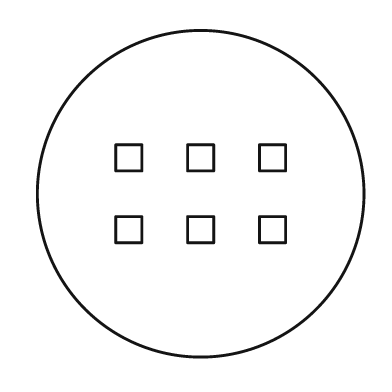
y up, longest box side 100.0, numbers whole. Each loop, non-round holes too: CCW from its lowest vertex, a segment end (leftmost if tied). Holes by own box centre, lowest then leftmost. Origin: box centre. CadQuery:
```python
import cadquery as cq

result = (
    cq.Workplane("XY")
    .moveTo(0.0, 0.0)
    .circle(50.0)
    .moveTo(-26.0, -15.0)
    .lineTo(-18.0, -15.0)
    .lineTo(-18.0, -7.0)
    .lineTo(-26.0, -7.0)
    .close()
    .moveTo(-4.0, -15.0)
    .lineTo(4.0, -15.0)
    .lineTo(4.0, -7.0)
    .lineTo(-4.0, -7.0)
    .close()
    .moveTo(18.0, -15.0)
    .lineTo(26.0, -15.0)
    .lineTo(26.0, -7.0)
    .lineTo(18.0, -7.0)
    .close()
    .moveTo(-26.0, 7.0)
    .lineTo(-18.0, 7.0)
    .lineTo(-18.0, 15.0)
    .lineTo(-26.0, 15.0)
    .close()
    .moveTo(-4.0, 7.0)
    .lineTo(4.0, 7.0)
    .lineTo(4.0, 15.0)
    .lineTo(-4.0, 15.0)
    .close()
    .moveTo(18.0, 7.0)
    .lineTo(26.0, 7.0)
    .lineTo(26.0, 15.0)
    .lineTo(18.0, 15.0)
    .close()
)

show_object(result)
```